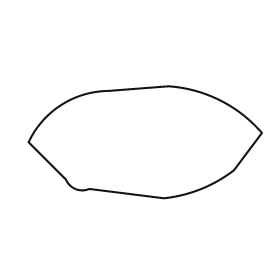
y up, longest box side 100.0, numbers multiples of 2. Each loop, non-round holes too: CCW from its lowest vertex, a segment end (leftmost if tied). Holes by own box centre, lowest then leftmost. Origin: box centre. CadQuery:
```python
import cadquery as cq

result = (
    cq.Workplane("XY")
    .moveTo(8.0, -24.0)
    .threePointArc((24.0, -20.0), (38.0, -12.0))
    .lineTo(50.0, 4.0)
    .threePointArc((32.0, 18.0), (10.0, 24.0))
    .lineTo(-16.0, 22.0)
    .threePointArc((-36.0, 16.0), (-50.0, 0.0))
    .lineTo(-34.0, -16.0)
    .threePointArc((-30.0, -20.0), (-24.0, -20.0))
    .close()
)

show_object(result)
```